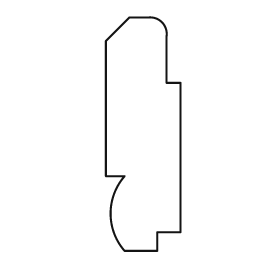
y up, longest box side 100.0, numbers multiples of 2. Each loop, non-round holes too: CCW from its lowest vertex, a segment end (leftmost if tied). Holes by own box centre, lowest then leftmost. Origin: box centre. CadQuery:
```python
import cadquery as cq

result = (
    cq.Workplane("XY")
    .moveTo(-8.0, -50.0)
    .lineTo(6.0, -50.0)
    .lineTo(6.0, -42.0)
    .lineTo(16.0, -42.0)
    .lineTo(16.0, 22.0)
    .lineTo(10.0, 22.0)
    .lineTo(10.0, 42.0)
    .threePointArc((8.0, 48.0), (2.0, 50.0))
    .lineTo(-6.0, 50.0)
    .lineTo(-16.0, 40.0)
    .lineTo(-16.0, -18.0)
    .lineTo(-8.0, -18.0)
    .threePointArc((-14.0, -34.0), (-8.0, -50.0))
    .close()
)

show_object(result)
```